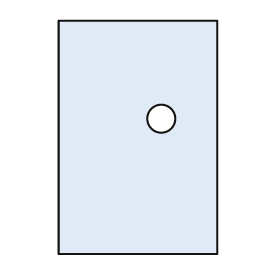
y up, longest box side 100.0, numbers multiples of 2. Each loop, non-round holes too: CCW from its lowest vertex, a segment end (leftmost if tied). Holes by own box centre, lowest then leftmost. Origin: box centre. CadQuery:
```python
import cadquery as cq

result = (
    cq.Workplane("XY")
    .moveTo(-34.0, -50.0)
    .lineTo(34.0, -50.0)
    .lineTo(34.0, 50.0)
    .lineTo(-34.0, 50.0)
    .close()
    .moveTo(10.0, 8.0)
    .circle(6.0)
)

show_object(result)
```